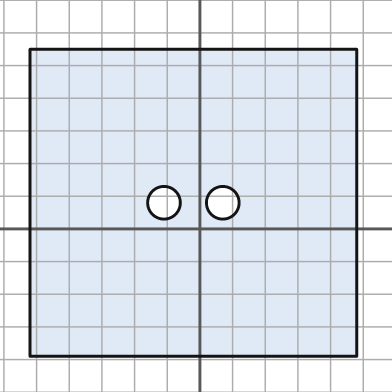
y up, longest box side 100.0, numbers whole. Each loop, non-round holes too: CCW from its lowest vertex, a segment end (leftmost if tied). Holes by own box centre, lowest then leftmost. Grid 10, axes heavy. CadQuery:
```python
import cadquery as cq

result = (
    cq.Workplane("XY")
    .moveTo(-52.0, -39.0)
    .lineTo(48.0, -39.0)
    .lineTo(48.0, 55.0)
    .lineTo(-52.0, 55.0)
    .close()
    .moveTo(-11.0, 8.0)
    .circle(5.0)
    .moveTo(7.0, 8.0)
    .circle(5.0)
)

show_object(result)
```